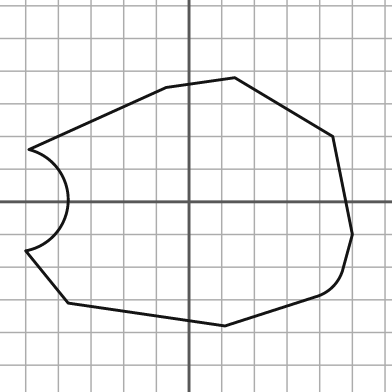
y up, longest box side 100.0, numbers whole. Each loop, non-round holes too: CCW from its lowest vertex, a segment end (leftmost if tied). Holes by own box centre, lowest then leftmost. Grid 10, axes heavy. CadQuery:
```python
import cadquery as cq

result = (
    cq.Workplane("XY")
    .moveTo(11.0, -38.0)
    .lineTo(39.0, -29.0)
    .threePointArc((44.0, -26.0), (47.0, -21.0))
    .lineTo(50.0, -10.0)
    .lineTo(44.0, 20.0)
    .lineTo(14.0, 38.0)
    .lineTo(-7.0, 35.0)
    .lineTo(-49.0, 16.0)
    .threePointArc((-37.0, 0.0), (-50.0, -15.0))
    .lineTo(-37.0, -31.0)
    .close()
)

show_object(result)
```